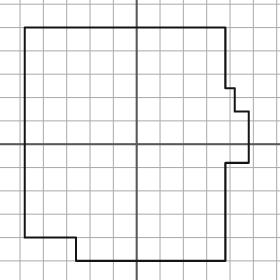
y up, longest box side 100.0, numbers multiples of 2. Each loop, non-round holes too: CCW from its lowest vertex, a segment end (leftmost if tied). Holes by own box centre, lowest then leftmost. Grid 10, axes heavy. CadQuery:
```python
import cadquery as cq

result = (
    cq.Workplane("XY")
    .moveTo(-26.0, -50.0)
    .lineTo(38.0, -50.0)
    .lineTo(38.0, -8.0)
    .lineTo(48.0, -8.0)
    .lineTo(48.0, 14.0)
    .lineTo(42.0, 14.0)
    .lineTo(42.0, 24.0)
    .lineTo(38.0, 24.0)
    .lineTo(38.0, 50.0)
    .lineTo(-48.0, 50.0)
    .lineTo(-48.0, -40.0)
    .lineTo(-26.0, -40.0)
    .close()
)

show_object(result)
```